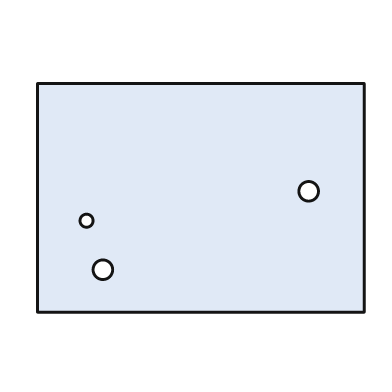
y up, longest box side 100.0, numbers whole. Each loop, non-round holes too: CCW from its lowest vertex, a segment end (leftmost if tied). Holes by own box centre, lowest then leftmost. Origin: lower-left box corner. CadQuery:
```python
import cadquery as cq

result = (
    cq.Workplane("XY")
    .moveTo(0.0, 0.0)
    .lineTo(100.0, 0.0)
    .lineTo(100.0, 70.0)
    .lineTo(0.0, 70.0)
    .close()
    .moveTo(20.0, 13.0)
    .circle(3.0)
    .moveTo(15.0, 28.0)
    .circle(2.0)
    .moveTo(83.0, 37.0)
    .circle(3.0)
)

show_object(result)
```